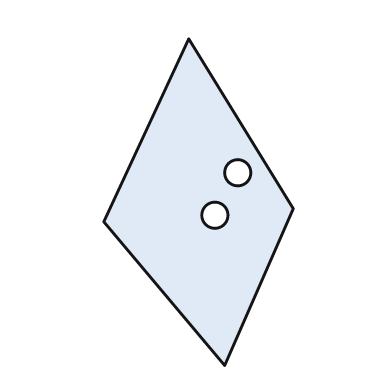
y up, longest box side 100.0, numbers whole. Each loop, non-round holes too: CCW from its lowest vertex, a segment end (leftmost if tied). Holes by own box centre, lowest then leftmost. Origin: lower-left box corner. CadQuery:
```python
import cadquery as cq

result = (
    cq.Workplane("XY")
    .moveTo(37.0, 0.0)
    .lineTo(58.0, 48.0)
    .lineTo(26.0, 100.0)
    .lineTo(0.0, 44.0)
    .close()
    .moveTo(34.0, 46.0)
    .circle(4.0)
    .moveTo(41.0, 59.0)
    .circle(4.0)
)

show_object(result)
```